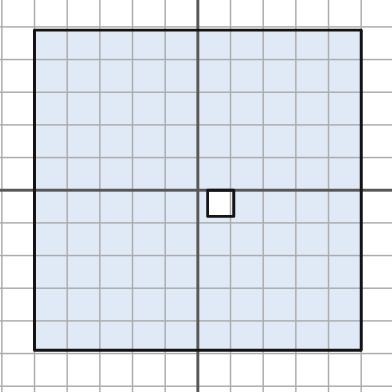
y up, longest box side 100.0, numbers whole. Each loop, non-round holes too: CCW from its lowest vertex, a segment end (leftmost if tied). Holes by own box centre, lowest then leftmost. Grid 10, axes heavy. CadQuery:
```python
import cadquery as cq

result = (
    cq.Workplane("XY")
    .moveTo(-50.0, -49.0)
    .lineTo(50.0, -49.0)
    .lineTo(50.0, 49.0)
    .lineTo(-50.0, 49.0)
    .close()
    .moveTo(3.0, -8.0)
    .lineTo(11.0, -8.0)
    .lineTo(11.0, 0.0)
    .lineTo(3.0, 0.0)
    .close()
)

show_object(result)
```